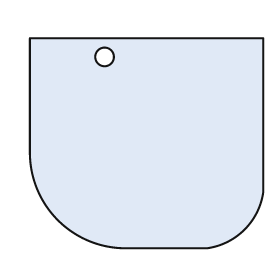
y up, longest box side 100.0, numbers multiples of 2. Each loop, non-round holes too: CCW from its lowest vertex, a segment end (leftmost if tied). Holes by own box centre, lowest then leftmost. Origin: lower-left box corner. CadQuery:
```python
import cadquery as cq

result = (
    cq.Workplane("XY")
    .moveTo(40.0, 0.0)
    .lineTo(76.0, 0.0)
    .threePointArc((92.0, 8.0), (100.0, 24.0))
    .lineTo(100.0, 90.0)
    .lineTo(0.0, 90.0)
    .lineTo(0.0, 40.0)
    .threePointArc((12.0, 12.0), (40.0, 0.0))
    .close()
    .moveTo(32.0, 82.0)
    .circle(4.0)
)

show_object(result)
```